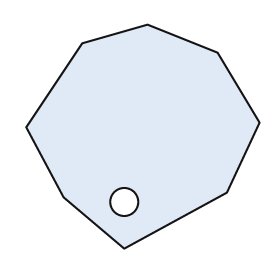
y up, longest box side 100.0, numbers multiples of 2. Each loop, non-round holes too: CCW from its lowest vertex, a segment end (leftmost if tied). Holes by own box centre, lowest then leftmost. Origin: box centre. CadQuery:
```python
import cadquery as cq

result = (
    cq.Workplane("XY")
    .moveTo(-8.0, -48.0)
    .lineTo(36.0, -24.0)
    .lineTo(50.0, 6.0)
    .lineTo(32.0, 36.0)
    .lineTo(2.0, 48.0)
    .lineTo(-26.0, 40.0)
    .lineTo(-50.0, 4.0)
    .lineTo(-34.0, -26.0)
    .close()
    .moveTo(-8.0, -28.0)
    .circle(6.0)
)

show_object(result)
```